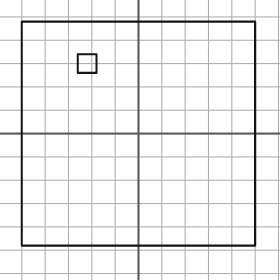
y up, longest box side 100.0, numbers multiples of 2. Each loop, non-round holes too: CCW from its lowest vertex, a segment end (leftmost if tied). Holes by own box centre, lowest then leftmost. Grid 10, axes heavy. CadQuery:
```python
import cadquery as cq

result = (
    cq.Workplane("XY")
    .moveTo(-50.0, -48.0)
    .lineTo(50.0, -48.0)
    .lineTo(50.0, 48.0)
    .lineTo(-50.0, 48.0)
    .close()
    .moveTo(-26.0, 26.0)
    .lineTo(-18.0, 26.0)
    .lineTo(-18.0, 34.0)
    .lineTo(-26.0, 34.0)
    .close()
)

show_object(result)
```